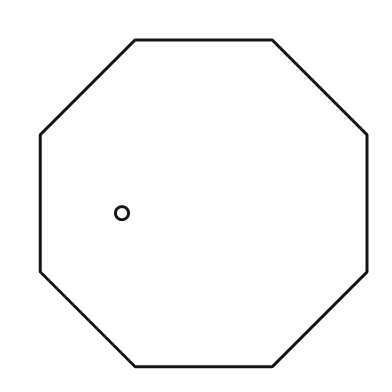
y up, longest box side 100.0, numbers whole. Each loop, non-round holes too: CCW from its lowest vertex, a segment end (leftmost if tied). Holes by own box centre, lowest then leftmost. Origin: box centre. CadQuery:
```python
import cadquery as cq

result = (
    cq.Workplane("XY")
    .moveTo(-21.0, -50.0)
    .lineTo(21.0, -50.0)
    .lineTo(50.0, -21.0)
    .lineTo(50.0, 21.0)
    .lineTo(21.0, 50.0)
    .lineTo(-21.0, 50.0)
    .lineTo(-50.0, 21.0)
    .lineTo(-50.0, -21.0)
    .close()
    .moveTo(-25.0, -3.0)
    .circle(2.0)
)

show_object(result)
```